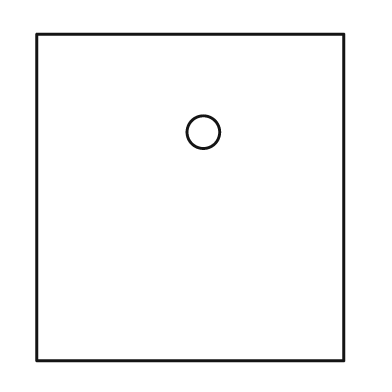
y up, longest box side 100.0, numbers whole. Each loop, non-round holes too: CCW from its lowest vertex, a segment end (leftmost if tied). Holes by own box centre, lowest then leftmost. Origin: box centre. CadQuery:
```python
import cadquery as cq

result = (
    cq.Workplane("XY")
    .moveTo(-47.0, -50.0)
    .lineTo(47.0, -50.0)
    .lineTo(47.0, 50.0)
    .lineTo(-47.0, 50.0)
    .close()
    .moveTo(4.0, 20.0)
    .circle(5.0)
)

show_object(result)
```